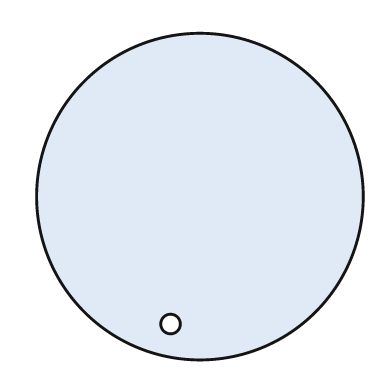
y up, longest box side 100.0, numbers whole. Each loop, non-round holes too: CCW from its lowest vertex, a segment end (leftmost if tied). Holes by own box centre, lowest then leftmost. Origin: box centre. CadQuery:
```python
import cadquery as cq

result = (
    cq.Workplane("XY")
    .moveTo(0.0, 0.0)
    .circle(50.0)
    .moveTo(-9.0, -39.0)
    .circle(3.0)
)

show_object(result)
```